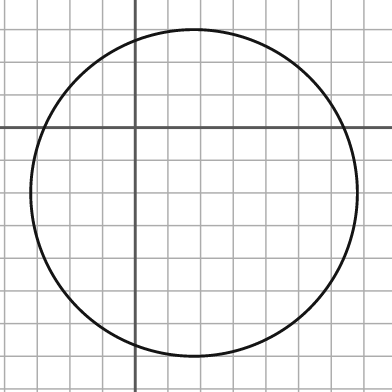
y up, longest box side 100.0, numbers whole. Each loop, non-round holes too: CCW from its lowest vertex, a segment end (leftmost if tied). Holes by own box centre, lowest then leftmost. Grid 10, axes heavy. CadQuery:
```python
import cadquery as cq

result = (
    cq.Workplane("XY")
    .moveTo(18.0, -20.0)
    .circle(50.0)
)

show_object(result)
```